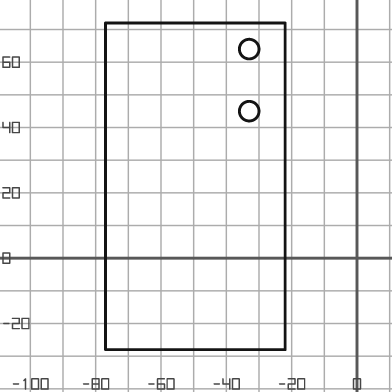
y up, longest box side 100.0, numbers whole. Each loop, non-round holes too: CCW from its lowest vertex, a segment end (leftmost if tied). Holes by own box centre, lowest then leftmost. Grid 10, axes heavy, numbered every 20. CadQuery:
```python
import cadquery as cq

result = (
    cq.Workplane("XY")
    .moveTo(-77.0, -28.0)
    .lineTo(-22.0, -28.0)
    .lineTo(-22.0, 72.0)
    .lineTo(-77.0, 72.0)
    .close()
    .moveTo(-33.0, 45.0)
    .circle(3.0)
    .moveTo(-33.0, 64.0)
    .circle(3.0)
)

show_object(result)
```